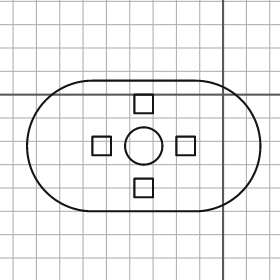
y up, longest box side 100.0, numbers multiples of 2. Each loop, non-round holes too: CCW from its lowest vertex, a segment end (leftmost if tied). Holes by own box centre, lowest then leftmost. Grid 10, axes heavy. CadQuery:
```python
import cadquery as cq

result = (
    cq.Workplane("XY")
    .moveTo(-56.0, -50.0)
    .lineTo(-12.0, -50.0)
    .threePointArc((16.0, -22.0), (-12.0, 6.0))
    .lineTo(-56.0, 6.0)
    .threePointArc((-84.0, -22.0), (-56.0, -50.0))
    .close()
    .moveTo(-38.0, -44.0)
    .lineTo(-30.0, -44.0)
    .lineTo(-30.0, -36.0)
    .lineTo(-38.0, -36.0)
    .close()
    .moveTo(-56.0, -26.0)
    .lineTo(-48.0, -26.0)
    .lineTo(-48.0, -18.0)
    .lineTo(-56.0, -18.0)
    .close()
    .moveTo(-34.0, -22.0)
    .circle(8.0)
    .moveTo(-20.0, -26.0)
    .lineTo(-12.0, -26.0)
    .lineTo(-12.0, -18.0)
    .lineTo(-20.0, -18.0)
    .close()
    .moveTo(-38.0, -8.0)
    .lineTo(-30.0, -8.0)
    .lineTo(-30.0, 0.0)
    .lineTo(-38.0, 0.0)
    .close()
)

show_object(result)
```